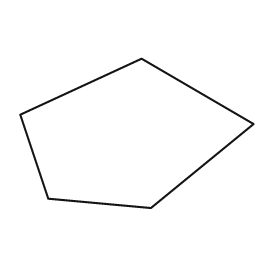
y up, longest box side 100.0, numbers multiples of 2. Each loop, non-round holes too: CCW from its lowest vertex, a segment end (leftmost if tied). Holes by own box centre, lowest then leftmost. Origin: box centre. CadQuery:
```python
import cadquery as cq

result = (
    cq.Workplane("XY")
    .moveTo(6.0, -32.0)
    .lineTo(50.0, 4.0)
    .lineTo(2.0, 32.0)
    .lineTo(-50.0, 8.0)
    .lineTo(-38.0, -28.0)
    .close()
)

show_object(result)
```